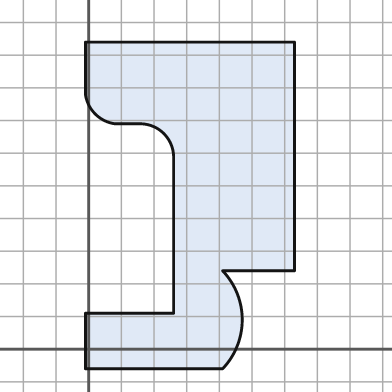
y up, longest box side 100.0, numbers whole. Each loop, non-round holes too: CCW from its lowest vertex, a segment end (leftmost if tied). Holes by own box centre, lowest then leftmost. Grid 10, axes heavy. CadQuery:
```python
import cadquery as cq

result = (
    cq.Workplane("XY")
    .moveTo(-1.0, -6.0)
    .lineTo(41.0, -6.0)
    .threePointArc((47.0, 9.0), (41.0, 24.0))
    .lineTo(63.0, 24.0)
    .lineTo(63.0, 94.0)
    .lineTo(-1.0, 94.0)
    .lineTo(-1.0, 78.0)
    .threePointArc((2.0, 72.0), (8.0, 69.0))
    .lineTo(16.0, 69.0)
    .threePointArc((23.0, 66.0), (26.0, 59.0))
    .lineTo(26.0, 11.0)
    .lineTo(-1.0, 11.0)
    .close()
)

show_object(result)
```